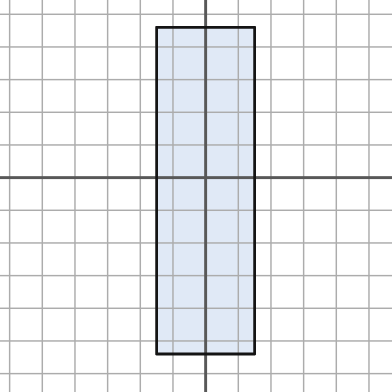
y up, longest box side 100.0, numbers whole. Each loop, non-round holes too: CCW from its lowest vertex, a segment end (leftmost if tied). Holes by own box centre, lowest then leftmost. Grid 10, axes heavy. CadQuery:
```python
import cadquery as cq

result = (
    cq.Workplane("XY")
    .moveTo(-15.0, -54.0)
    .lineTo(15.0, -54.0)
    .lineTo(15.0, 46.0)
    .lineTo(-15.0, 46.0)
    .close()
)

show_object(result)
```